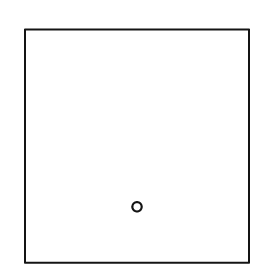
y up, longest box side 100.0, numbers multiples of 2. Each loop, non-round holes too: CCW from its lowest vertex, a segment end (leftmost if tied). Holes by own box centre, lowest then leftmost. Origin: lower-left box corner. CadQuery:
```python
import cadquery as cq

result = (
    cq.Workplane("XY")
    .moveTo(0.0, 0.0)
    .lineTo(96.0, 0.0)
    .lineTo(96.0, 100.0)
    .lineTo(0.0, 100.0)
    .close()
    .moveTo(48.0, 24.0)
    .circle(2.0)
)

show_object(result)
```